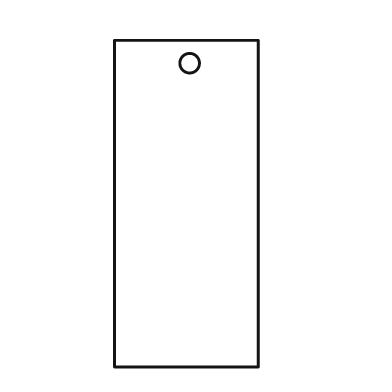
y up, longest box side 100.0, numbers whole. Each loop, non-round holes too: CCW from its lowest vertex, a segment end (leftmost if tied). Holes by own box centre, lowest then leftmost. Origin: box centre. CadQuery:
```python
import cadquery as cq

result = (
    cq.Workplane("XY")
    .moveTo(-22.0, -50.0)
    .lineTo(22.0, -50.0)
    .lineTo(22.0, 50.0)
    .lineTo(-22.0, 50.0)
    .close()
    .moveTo(1.0, 43.0)
    .circle(3.0)
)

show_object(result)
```